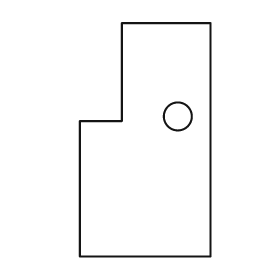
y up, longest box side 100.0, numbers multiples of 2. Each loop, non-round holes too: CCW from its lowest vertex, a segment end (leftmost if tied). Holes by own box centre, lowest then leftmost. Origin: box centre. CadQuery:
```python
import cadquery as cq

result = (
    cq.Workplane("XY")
    .moveTo(-28.0, -50.0)
    .lineTo(28.0, -50.0)
    .lineTo(28.0, 50.0)
    .lineTo(-10.0, 50.0)
    .lineTo(-10.0, 8.0)
    .lineTo(-28.0, 8.0)
    .close()
    .moveTo(14.0, 10.0)
    .circle(6.0)
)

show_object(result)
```